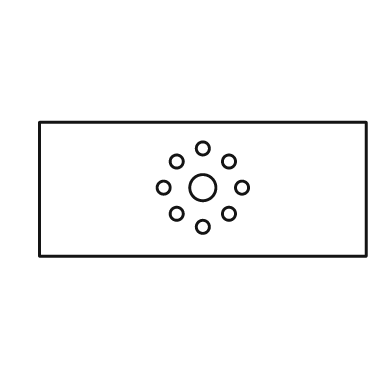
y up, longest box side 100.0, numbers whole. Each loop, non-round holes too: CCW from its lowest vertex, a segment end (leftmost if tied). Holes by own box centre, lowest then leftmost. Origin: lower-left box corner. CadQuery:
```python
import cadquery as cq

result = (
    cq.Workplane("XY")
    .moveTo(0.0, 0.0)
    .lineTo(100.0, 0.0)
    .lineTo(100.0, 41.0)
    .lineTo(0.0, 41.0)
    .close()
    .moveTo(50.0, 9.0)
    .circle(2.0)
    .moveTo(42.0, 13.0)
    .circle(2.0)
    .moveTo(58.0, 13.0)
    .circle(2.0)
    .moveTo(38.0, 21.0)
    .circle(2.0)
    .moveTo(50.0, 21.0)
    .circle(4.0)
    .moveTo(62.0, 21.0)
    .circle(2.0)
    .moveTo(42.0, 29.0)
    .circle(2.0)
    .moveTo(58.0, 29.0)
    .circle(2.0)
    .moveTo(50.0, 33.0)
    .circle(2.0)
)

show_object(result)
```